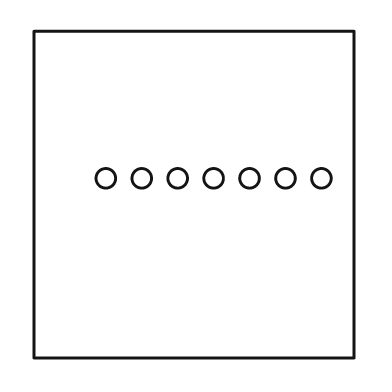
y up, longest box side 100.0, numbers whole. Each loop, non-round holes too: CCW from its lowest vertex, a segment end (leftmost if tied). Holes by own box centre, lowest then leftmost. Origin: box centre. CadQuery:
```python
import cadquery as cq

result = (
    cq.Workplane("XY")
    .moveTo(-49.0, -50.0)
    .lineTo(49.0, -50.0)
    .lineTo(49.0, 50.0)
    .lineTo(-49.0, 50.0)
    .close()
    .moveTo(-27.0, 5.0)
    .circle(3.0)
    .moveTo(-16.0, 5.0)
    .circle(3.0)
    .moveTo(-5.0, 5.0)
    .circle(3.0)
    .moveTo(6.0, 5.0)
    .circle(3.0)
    .moveTo(17.0, 5.0)
    .circle(3.0)
    .moveTo(28.0, 5.0)
    .circle(3.0)
    .moveTo(39.0, 5.0)
    .circle(3.0)
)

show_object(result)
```